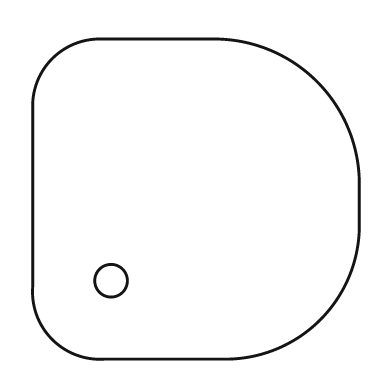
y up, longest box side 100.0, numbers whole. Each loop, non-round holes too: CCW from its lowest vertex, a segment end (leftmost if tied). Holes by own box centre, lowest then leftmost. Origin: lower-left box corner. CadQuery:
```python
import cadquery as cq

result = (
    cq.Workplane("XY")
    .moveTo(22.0, 0.0)
    .lineTo(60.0, 0.0)
    .threePointArc((88.0, 12.0), (100.0, 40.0))
    .lineTo(100.0, 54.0)
    .threePointArc((87.0, 85.0), (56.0, 98.0))
    .lineTo(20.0, 98.0)
    .threePointArc((6.0, 92.0), (0.0, 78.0))
    .lineTo(0.0, 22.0)
    .threePointArc((6.0, 6.0), (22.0, 0.0))
    .close()
    .moveTo(24.0, 24.0)
    .circle(5.0)
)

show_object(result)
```